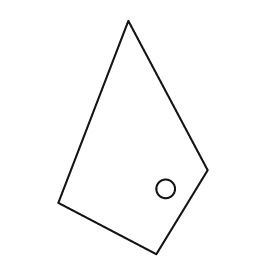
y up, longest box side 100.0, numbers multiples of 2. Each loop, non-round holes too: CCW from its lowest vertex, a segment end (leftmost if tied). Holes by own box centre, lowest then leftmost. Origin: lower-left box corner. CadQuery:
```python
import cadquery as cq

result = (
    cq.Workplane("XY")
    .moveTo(42.0, 0.0)
    .lineTo(64.0, 36.0)
    .lineTo(30.0, 100.0)
    .lineTo(0.0, 22.0)
    .close()
    .moveTo(46.0, 28.0)
    .circle(4.0)
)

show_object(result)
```